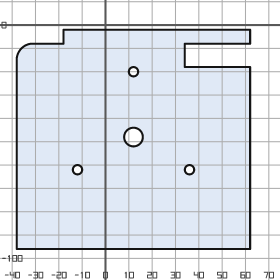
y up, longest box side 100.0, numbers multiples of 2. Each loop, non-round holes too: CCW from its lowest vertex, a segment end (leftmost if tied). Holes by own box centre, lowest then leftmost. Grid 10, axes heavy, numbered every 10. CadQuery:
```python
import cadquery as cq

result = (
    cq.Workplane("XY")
    .moveTo(-38.0, -96.0)
    .lineTo(62.0, -96.0)
    .lineTo(62.0, -18.0)
    .lineTo(34.0, -18.0)
    .lineTo(34.0, -8.0)
    .lineTo(62.0, -8.0)
    .lineTo(62.0, -2.0)
    .lineTo(-18.0, -2.0)
    .lineTo(-18.0, -8.0)
    .lineTo(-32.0, -8.0)
    .threePointArc((-36.0, -10.0), (-38.0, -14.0))
    .close()
    .moveTo(-12.0, -62.0)
    .circle(2.0)
    .moveTo(36.0, -62.0)
    .circle(2.0)
    .moveTo(12.0, -48.0)
    .circle(4.0)
    .moveTo(12.0, -20.0)
    .circle(2.0)
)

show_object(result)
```